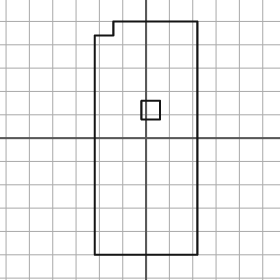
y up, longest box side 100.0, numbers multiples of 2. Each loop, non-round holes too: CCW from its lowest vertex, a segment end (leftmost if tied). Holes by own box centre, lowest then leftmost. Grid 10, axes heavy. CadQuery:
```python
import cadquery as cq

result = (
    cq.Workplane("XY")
    .moveTo(-22.0, -50.0)
    .lineTo(22.0, -50.0)
    .lineTo(22.0, 50.0)
    .lineTo(-14.0, 50.0)
    .lineTo(-14.0, 44.0)
    .lineTo(-22.0, 44.0)
    .close()
    .moveTo(-2.0, 8.0)
    .lineTo(6.0, 8.0)
    .lineTo(6.0, 16.0)
    .lineTo(-2.0, 16.0)
    .close()
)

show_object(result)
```